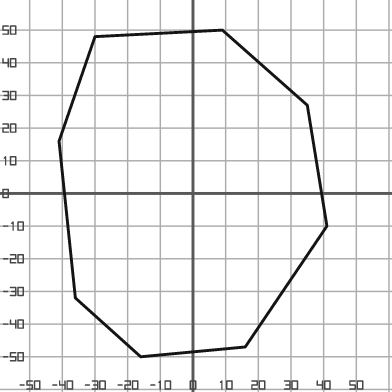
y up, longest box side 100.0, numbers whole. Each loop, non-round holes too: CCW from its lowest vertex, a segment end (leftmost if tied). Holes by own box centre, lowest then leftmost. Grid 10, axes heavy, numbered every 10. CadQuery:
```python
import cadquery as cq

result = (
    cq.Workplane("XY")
    .moveTo(-16.0, -50.0)
    .lineTo(16.0, -47.0)
    .lineTo(41.0, -10.0)
    .lineTo(35.0, 27.0)
    .lineTo(9.0, 50.0)
    .lineTo(-30.0, 48.0)
    .lineTo(-41.0, 16.0)
    .lineTo(-36.0, -32.0)
    .close()
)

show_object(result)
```